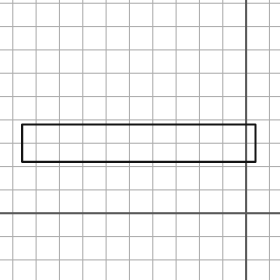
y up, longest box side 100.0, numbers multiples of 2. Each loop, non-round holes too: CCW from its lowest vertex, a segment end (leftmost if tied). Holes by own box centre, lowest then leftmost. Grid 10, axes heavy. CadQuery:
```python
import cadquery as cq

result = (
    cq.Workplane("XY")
    .moveTo(-96.0, 22.0)
    .lineTo(4.0, 22.0)
    .lineTo(4.0, 38.0)
    .lineTo(-96.0, 38.0)
    .close()
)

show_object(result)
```